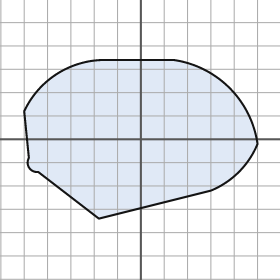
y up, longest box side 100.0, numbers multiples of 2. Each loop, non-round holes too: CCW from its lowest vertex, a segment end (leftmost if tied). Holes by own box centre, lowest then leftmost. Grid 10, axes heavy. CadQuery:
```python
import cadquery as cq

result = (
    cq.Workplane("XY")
    .moveTo(-18.0, -34.0)
    .lineTo(30.0, -22.0)
    .threePointArc((42.0, -14.0), (50.0, -2.0))
    .threePointArc((38.0, 22.0), (14.0, 34.0))
    .lineTo(-16.0, 34.0)
    .threePointArc((-36.0, 28.0), (-50.0, 12.0))
    .lineTo(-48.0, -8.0)
    .threePointArc((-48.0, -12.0), (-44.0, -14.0))
    .close()
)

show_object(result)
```